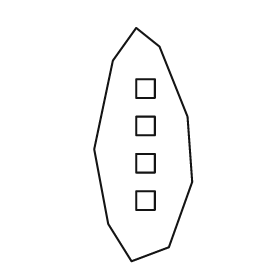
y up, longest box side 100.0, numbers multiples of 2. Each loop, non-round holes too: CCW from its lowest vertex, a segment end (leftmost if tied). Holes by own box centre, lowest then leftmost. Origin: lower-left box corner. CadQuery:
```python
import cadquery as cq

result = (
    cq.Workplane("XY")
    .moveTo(16.0, 0.0)
    .lineTo(32.0, 6.0)
    .lineTo(42.0, 34.0)
    .lineTo(40.0, 62.0)
    .lineTo(28.0, 92.0)
    .lineTo(18.0, 100.0)
    .lineTo(8.0, 86.0)
    .lineTo(0.0, 48.0)
    .lineTo(6.0, 16.0)
    .close()
    .moveTo(18.0, 22.0)
    .lineTo(26.0, 22.0)
    .lineTo(26.0, 30.0)
    .lineTo(18.0, 30.0)
    .close()
    .moveTo(18.0, 38.0)
    .lineTo(26.0, 38.0)
    .lineTo(26.0, 46.0)
    .lineTo(18.0, 46.0)
    .close()
    .moveTo(18.0, 54.0)
    .lineTo(26.0, 54.0)
    .lineTo(26.0, 62.0)
    .lineTo(18.0, 62.0)
    .close()
    .moveTo(18.0, 70.0)
    .lineTo(26.0, 70.0)
    .lineTo(26.0, 78.0)
    .lineTo(18.0, 78.0)
    .close()
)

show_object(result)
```